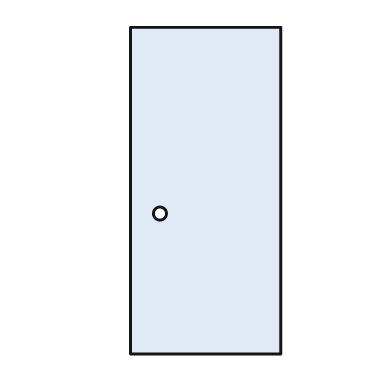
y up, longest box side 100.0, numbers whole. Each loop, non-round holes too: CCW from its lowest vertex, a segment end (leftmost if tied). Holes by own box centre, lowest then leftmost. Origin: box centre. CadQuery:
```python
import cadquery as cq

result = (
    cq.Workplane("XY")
    .moveTo(-23.0, -50.0)
    .lineTo(23.0, -50.0)
    .lineTo(23.0, 50.0)
    .lineTo(-23.0, 50.0)
    .close()
    .moveTo(-14.0, -7.0)
    .circle(2.0)
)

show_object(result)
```